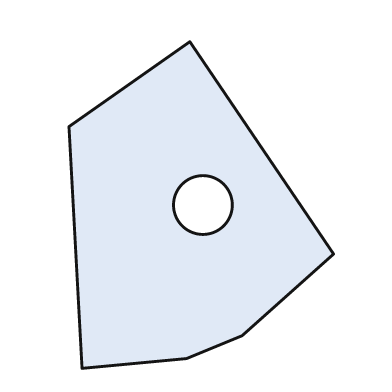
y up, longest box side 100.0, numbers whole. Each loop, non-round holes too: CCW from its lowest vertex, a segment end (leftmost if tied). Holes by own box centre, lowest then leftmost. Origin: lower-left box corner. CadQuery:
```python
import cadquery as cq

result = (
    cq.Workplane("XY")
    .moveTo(4.0, 0.0)
    .lineTo(36.0, 3.0)
    .lineTo(53.0, 10.0)
    .lineTo(81.0, 35.0)
    .lineTo(37.0, 100.0)
    .lineTo(0.0, 74.0)
    .close()
    .moveTo(41.0, 50.0)
    .circle(9.0)
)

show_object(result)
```